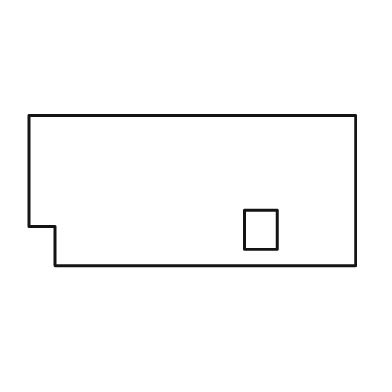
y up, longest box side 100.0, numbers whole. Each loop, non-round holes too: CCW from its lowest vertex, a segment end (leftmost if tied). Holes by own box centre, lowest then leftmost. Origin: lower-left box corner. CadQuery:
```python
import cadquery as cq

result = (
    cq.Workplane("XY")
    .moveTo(8.0, 0.0)
    .lineTo(100.0, 0.0)
    .lineTo(100.0, 46.0)
    .lineTo(0.0, 46.0)
    .lineTo(0.0, 12.0)
    .lineTo(8.0, 12.0)
    .close()
    .moveTo(66.0, 5.0)
    .lineTo(76.0, 5.0)
    .lineTo(76.0, 17.0)
    .lineTo(66.0, 17.0)
    .close()
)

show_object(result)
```